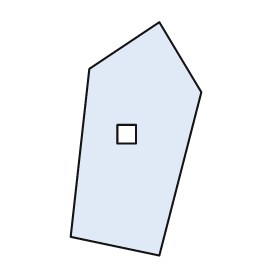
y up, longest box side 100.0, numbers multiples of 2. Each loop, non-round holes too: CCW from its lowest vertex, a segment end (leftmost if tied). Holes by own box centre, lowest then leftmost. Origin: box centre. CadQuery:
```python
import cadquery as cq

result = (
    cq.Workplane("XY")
    .moveTo(10.0, -50.0)
    .lineTo(28.0, 20.0)
    .lineTo(10.0, 50.0)
    .lineTo(-20.0, 30.0)
    .lineTo(-28.0, -42.0)
    .close()
    .moveTo(-8.0, -2.0)
    .lineTo(0.0, -2.0)
    .lineTo(0.0, 6.0)
    .lineTo(-8.0, 6.0)
    .close()
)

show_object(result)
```